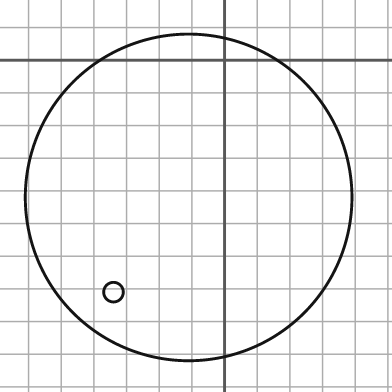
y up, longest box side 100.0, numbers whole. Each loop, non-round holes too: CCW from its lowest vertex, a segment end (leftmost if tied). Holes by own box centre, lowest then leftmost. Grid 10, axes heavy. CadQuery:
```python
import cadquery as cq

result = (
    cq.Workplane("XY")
    .moveTo(-11.0, -42.0)
    .circle(50.0)
    .moveTo(-34.0, -71.0)
    .circle(3.0)
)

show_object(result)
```